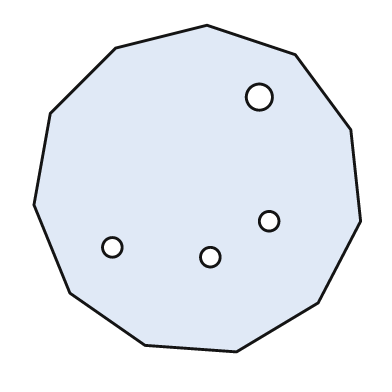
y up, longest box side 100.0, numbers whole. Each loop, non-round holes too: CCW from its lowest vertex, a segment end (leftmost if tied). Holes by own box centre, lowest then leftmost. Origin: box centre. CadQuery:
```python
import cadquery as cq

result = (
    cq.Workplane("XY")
    .moveTo(12.0, -50.0)
    .lineTo(37.0, -35.0)
    .lineTo(50.0, -10.0)
    .lineTo(47.0, 18.0)
    .lineTo(30.0, 41.0)
    .lineTo(3.0, 50.0)
    .lineTo(-25.0, 43.0)
    .lineTo(-45.0, 23.0)
    .lineTo(-50.0, -5.0)
    .lineTo(-39.0, -32.0)
    .lineTo(-16.0, -48.0)
    .close()
    .moveTo(4.0, -21.0)
    .circle(3.0)
    .moveTo(-26.0, -18.0)
    .circle(3.0)
    .moveTo(22.0, -10.0)
    .circle(3.0)
    .moveTo(19.0, 28.0)
    .circle(4.0)
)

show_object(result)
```